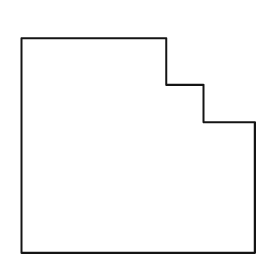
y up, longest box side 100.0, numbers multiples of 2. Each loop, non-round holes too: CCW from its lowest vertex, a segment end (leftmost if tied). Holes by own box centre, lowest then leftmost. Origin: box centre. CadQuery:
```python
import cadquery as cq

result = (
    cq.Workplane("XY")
    .moveTo(-50.0, -46.0)
    .lineTo(50.0, -46.0)
    .lineTo(50.0, 10.0)
    .lineTo(28.0, 10.0)
    .lineTo(28.0, 26.0)
    .lineTo(12.0, 26.0)
    .lineTo(12.0, 46.0)
    .lineTo(-50.0, 46.0)
    .close()
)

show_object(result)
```